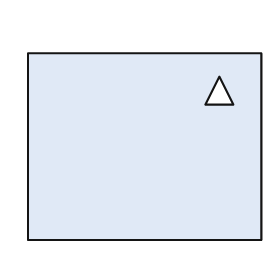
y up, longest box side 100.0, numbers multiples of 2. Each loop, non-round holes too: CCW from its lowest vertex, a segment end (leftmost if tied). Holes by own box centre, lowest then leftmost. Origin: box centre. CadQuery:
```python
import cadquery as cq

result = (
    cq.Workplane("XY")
    .moveTo(-50.0, -40.0)
    .lineTo(50.0, -40.0)
    .lineTo(50.0, 40.0)
    .lineTo(-50.0, 40.0)
    .close()
    .moveTo(26.0, 18.0)
    .lineTo(38.0, 18.0)
    .lineTo(32.0, 30.0)
    .close()
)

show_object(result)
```